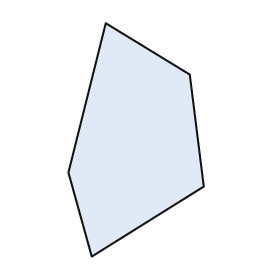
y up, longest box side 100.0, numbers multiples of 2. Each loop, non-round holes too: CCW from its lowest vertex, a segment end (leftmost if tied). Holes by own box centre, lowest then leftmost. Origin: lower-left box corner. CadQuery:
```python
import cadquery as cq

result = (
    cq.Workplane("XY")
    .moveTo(10.0, 0.0)
    .lineTo(58.0, 30.0)
    .lineTo(52.0, 78.0)
    .lineTo(16.0, 100.0)
    .lineTo(0.0, 36.0)
    .close()
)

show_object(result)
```